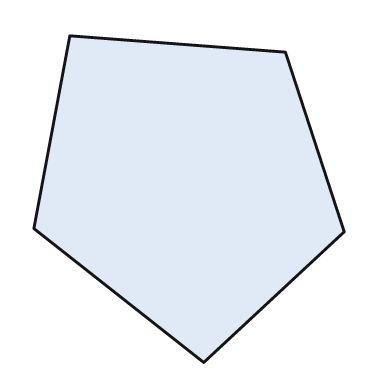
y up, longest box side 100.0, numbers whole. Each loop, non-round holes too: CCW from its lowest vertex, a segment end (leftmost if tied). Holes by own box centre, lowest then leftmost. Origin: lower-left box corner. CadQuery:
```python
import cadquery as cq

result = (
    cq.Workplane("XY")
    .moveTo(52.0, 0.0)
    .lineTo(95.0, 40.0)
    .lineTo(77.0, 95.0)
    .lineTo(11.0, 100.0)
    .lineTo(0.0, 41.0)
    .close()
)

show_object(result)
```